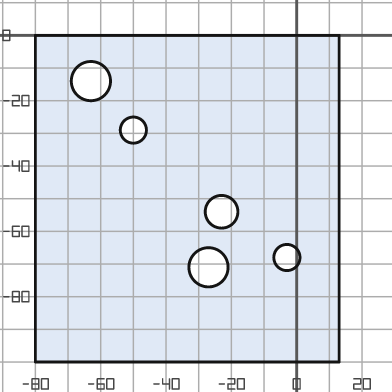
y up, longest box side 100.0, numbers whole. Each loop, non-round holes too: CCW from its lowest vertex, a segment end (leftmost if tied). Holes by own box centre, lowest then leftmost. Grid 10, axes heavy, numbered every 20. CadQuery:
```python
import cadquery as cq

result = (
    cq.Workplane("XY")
    .moveTo(-80.0, -100.0)
    .lineTo(13.0, -100.0)
    .lineTo(13.0, 0.0)
    .lineTo(-80.0, 0.0)
    .close()
    .moveTo(-27.0, -71.0)
    .circle(6.0)
    .moveTo(-3.0, -68.0)
    .circle(4.0)
    .moveTo(-23.0, -54.0)
    .circle(5.0)
    .moveTo(-50.0, -29.0)
    .circle(4.0)
    .moveTo(-63.0, -14.0)
    .circle(6.0)
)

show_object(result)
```